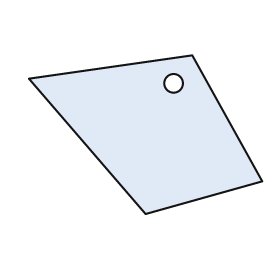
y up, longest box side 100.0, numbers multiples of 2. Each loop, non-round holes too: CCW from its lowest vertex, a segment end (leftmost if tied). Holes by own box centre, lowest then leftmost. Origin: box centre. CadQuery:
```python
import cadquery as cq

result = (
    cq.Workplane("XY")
    .moveTo(0.0, -34.0)
    .lineTo(50.0, -20.0)
    .lineTo(20.0, 34.0)
    .lineTo(-50.0, 24.0)
    .close()
    .moveTo(12.0, 22.0)
    .circle(4.0)
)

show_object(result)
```